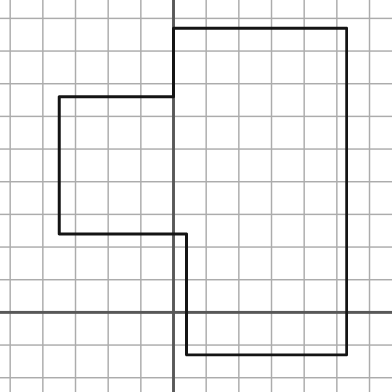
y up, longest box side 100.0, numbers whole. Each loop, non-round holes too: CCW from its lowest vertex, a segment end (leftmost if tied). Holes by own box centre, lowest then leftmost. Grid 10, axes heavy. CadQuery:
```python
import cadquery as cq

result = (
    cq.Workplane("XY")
    .moveTo(4.0, -13.0)
    .lineTo(53.0, -13.0)
    .lineTo(53.0, 87.0)
    .lineTo(0.0, 87.0)
    .lineTo(0.0, 66.0)
    .lineTo(-35.0, 66.0)
    .lineTo(-35.0, 24.0)
    .lineTo(4.0, 24.0)
    .close()
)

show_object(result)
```